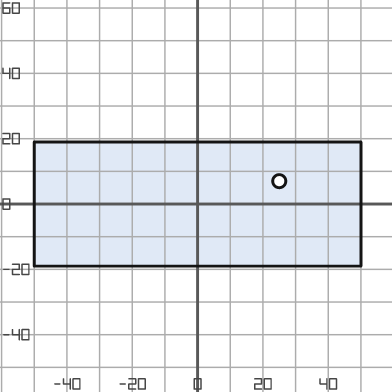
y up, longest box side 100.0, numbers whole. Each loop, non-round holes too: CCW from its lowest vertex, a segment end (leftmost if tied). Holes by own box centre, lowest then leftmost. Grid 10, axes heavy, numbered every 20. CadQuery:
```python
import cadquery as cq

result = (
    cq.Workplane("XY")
    .moveTo(-50.0, -19.0)
    .lineTo(50.0, -19.0)
    .lineTo(50.0, 19.0)
    .lineTo(-50.0, 19.0)
    .close()
    .moveTo(25.0, 7.0)
    .circle(2.0)
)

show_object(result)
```